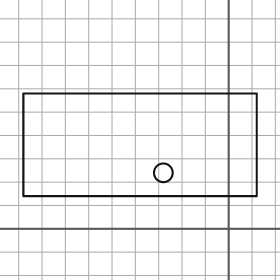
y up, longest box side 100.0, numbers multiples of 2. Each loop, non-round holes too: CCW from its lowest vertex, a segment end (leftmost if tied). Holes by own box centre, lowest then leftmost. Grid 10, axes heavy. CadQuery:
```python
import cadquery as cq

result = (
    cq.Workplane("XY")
    .moveTo(-88.0, 14.0)
    .lineTo(12.0, 14.0)
    .lineTo(12.0, 58.0)
    .lineTo(-88.0, 58.0)
    .close()
    .moveTo(-28.0, 24.0)
    .circle(4.0)
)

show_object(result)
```